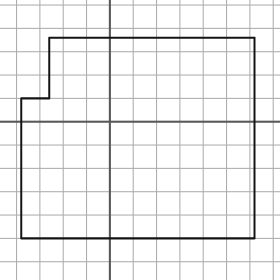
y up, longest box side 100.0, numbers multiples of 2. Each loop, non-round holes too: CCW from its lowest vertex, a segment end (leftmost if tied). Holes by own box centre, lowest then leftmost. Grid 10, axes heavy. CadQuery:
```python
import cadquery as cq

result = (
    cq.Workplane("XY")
    .moveTo(-38.0, -50.0)
    .lineTo(62.0, -50.0)
    .lineTo(62.0, 36.0)
    .lineTo(-26.0, 36.0)
    .lineTo(-26.0, 10.0)
    .lineTo(-38.0, 10.0)
    .close()
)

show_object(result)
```